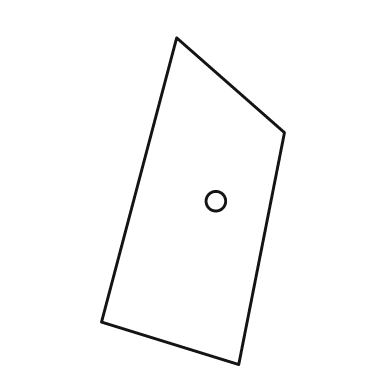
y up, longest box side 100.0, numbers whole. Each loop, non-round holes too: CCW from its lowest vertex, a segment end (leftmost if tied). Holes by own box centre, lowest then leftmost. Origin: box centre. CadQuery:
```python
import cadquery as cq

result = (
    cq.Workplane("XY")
    .moveTo(14.0, -50.0)
    .lineTo(28.0, 21.0)
    .lineTo(-5.0, 50.0)
    .lineTo(-28.0, -37.0)
    .close()
    .moveTo(7.0, 0.0)
    .circle(3.0)
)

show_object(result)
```